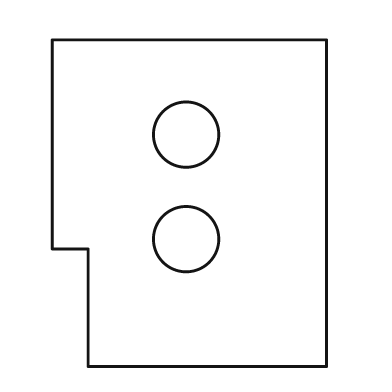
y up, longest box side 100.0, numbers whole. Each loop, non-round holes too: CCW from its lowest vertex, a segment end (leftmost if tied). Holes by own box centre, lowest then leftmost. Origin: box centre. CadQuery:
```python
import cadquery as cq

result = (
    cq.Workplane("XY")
    .moveTo(-31.0, -50.0)
    .lineTo(42.0, -50.0)
    .lineTo(42.0, 50.0)
    .lineTo(-42.0, 50.0)
    .lineTo(-42.0, -14.0)
    .lineTo(-31.0, -14.0)
    .close()
    .moveTo(-1.0, -11.0)
    .circle(10.0)
    .moveTo(-1.0, 21.0)
    .circle(10.0)
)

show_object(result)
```